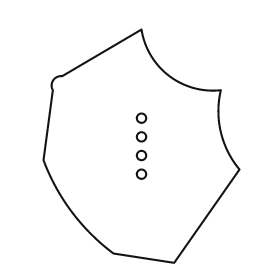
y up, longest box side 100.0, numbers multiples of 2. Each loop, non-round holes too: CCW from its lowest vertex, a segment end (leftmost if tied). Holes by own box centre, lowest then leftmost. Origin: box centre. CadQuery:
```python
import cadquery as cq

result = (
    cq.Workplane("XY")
    .moveTo(14.0, -50.0)
    .lineTo(42.0, -10.0)
    .threePointArc((34.0, 6.0), (34.0, 24.0))
    .threePointArc((12.0, 30.0), (0.0, 50.0))
    .lineTo(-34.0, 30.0)
    .threePointArc((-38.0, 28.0), (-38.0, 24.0))
    .lineTo(-42.0, -6.0)
    .threePointArc((-30.0, -28.0), (-12.0, -46.0))
    .close()
    .moveTo(0.0, -12.0)
    .circle(2.0)
    .moveTo(0.0, -4.0)
    .circle(2.0)
    .moveTo(0.0, 4.0)
    .circle(2.0)
    .moveTo(0.0, 12.0)
    .circle(2.0)
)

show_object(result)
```